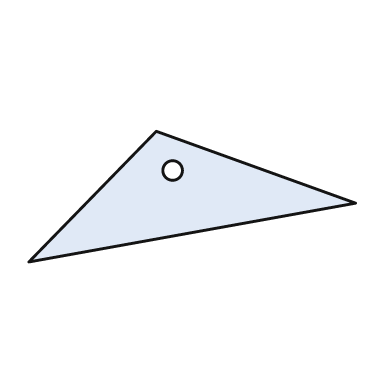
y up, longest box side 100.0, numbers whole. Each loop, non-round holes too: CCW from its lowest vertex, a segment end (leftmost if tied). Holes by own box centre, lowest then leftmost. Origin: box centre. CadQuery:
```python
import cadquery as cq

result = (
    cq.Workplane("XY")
    .moveTo(-50.0, -20.0)
    .lineTo(50.0, -2.0)
    .lineTo(-11.0, 20.0)
    .close()
    .moveTo(-6.0, 8.0)
    .circle(3.0)
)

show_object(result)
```